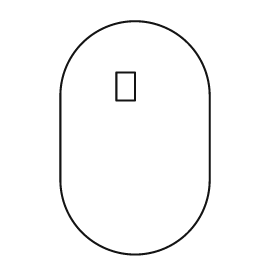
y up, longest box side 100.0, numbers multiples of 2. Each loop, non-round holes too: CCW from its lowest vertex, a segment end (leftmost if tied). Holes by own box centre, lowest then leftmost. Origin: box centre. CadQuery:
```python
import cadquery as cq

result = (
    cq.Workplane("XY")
    .moveTo(-32.0, -18.0)
    .threePointArc((0.0, -50.0), (32.0, -18.0))
    .lineTo(32.0, 18.0)
    .threePointArc((0.0, 50.0), (-32.0, 18.0))
    .close()
    .moveTo(-8.0, 16.0)
    .lineTo(0.0, 16.0)
    .lineTo(0.0, 28.0)
    .lineTo(-8.0, 28.0)
    .close()
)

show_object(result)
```